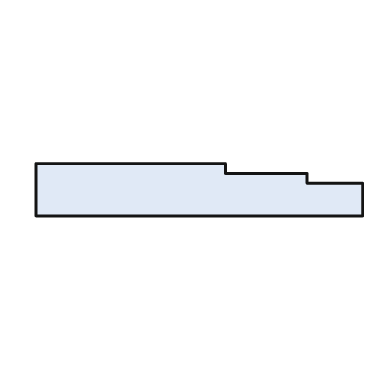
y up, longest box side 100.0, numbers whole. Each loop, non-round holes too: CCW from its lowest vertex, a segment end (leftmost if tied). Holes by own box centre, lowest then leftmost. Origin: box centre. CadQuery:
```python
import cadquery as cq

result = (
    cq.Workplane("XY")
    .moveTo(-50.0, -8.0)
    .lineTo(50.0, -8.0)
    .lineTo(50.0, 2.0)
    .lineTo(33.0, 2.0)
    .lineTo(33.0, 5.0)
    .lineTo(8.0, 5.0)
    .lineTo(8.0, 8.0)
    .lineTo(-50.0, 8.0)
    .close()
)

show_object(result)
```